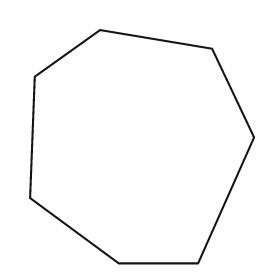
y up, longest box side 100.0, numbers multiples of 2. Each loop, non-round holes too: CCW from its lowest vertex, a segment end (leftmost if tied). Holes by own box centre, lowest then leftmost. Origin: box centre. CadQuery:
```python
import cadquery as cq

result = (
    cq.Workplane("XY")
    .moveTo(-10.0, -50.0)
    .lineTo(24.0, -50.0)
    .lineTo(48.0, 4.0)
    .lineTo(30.0, 42.0)
    .lineTo(-18.0, 50.0)
    .lineTo(-46.0, 30.0)
    .lineTo(-48.0, -22.0)
    .close()
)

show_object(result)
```